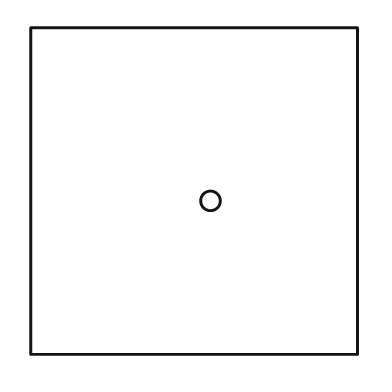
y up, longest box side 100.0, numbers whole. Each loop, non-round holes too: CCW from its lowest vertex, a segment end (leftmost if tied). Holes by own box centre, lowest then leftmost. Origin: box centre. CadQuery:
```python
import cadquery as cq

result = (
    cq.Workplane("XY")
    .moveTo(-50.0, -50.0)
    .lineTo(50.0, -50.0)
    .lineTo(50.0, 50.0)
    .lineTo(-50.0, 50.0)
    .close()
    .moveTo(5.0, -3.0)
    .circle(3.0)
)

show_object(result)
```